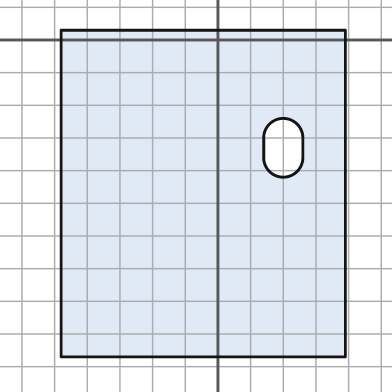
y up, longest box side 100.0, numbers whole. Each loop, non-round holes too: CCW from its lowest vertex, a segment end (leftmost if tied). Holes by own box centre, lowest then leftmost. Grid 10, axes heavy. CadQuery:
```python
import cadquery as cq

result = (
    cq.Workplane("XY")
    .moveTo(-48.0, -97.0)
    .lineTo(39.0, -97.0)
    .lineTo(39.0, 3.0)
    .lineTo(-48.0, 3.0)
    .close()
    .moveTo(14.0, -36.0)
    .threePointArc((20.0, -42.0), (26.0, -36.0))
    .lineTo(26.0, -30.0)
    .threePointArc((20.0, -24.0), (14.0, -30.0))
    .close()
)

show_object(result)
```